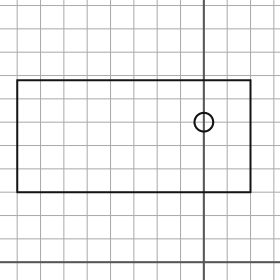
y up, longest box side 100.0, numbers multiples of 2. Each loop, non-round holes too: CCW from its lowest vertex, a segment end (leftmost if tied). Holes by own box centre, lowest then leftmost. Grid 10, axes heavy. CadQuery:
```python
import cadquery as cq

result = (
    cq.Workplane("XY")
    .moveTo(-80.0, 30.0)
    .lineTo(20.0, 30.0)
    .lineTo(20.0, 78.0)
    .lineTo(-80.0, 78.0)
    .close()
    .moveTo(0.0, 60.0)
    .circle(4.0)
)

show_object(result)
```